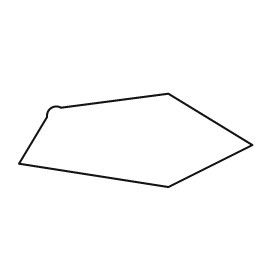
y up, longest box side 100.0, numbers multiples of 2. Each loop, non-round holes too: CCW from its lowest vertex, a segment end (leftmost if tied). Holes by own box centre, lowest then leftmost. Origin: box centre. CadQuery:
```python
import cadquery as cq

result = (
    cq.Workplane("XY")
    .moveTo(14.0, -20.0)
    .lineTo(50.0, -2.0)
    .lineTo(14.0, 20.0)
    .lineTo(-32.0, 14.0)
    .threePointArc((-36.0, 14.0), (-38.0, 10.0))
    .lineTo(-50.0, -10.0)
    .close()
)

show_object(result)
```